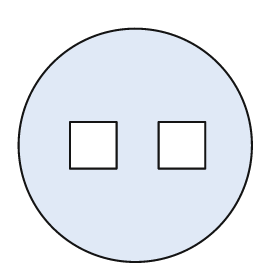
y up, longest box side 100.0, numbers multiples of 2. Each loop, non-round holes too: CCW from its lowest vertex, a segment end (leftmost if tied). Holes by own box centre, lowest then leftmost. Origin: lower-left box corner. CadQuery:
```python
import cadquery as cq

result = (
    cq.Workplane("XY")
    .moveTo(50.0, 50.0)
    .circle(50.0)
    .moveTo(22.0, 40.0)
    .lineTo(42.0, 40.0)
    .lineTo(42.0, 60.0)
    .lineTo(22.0, 60.0)
    .close()
    .moveTo(60.0, 40.0)
    .lineTo(80.0, 40.0)
    .lineTo(80.0, 60.0)
    .lineTo(60.0, 60.0)
    .close()
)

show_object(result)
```